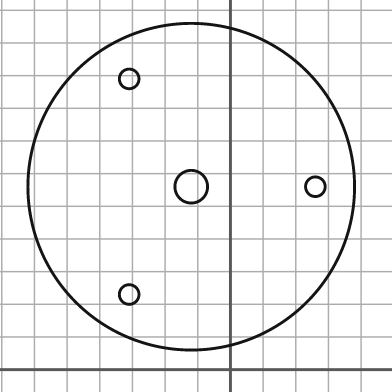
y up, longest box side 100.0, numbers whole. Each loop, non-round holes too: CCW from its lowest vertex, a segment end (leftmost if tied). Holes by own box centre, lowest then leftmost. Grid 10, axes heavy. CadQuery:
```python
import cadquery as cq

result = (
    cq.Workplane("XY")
    .moveTo(-12.0, 56.0)
    .circle(50.0)
    .moveTo(-31.0, 23.0)
    .circle(3.0)
    .moveTo(-12.0, 56.0)
    .circle(5.0)
    .moveTo(26.0, 56.0)
    .circle(3.0)
    .moveTo(-31.0, 89.0)
    .circle(3.0)
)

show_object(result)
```